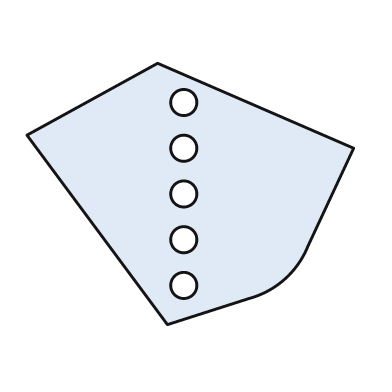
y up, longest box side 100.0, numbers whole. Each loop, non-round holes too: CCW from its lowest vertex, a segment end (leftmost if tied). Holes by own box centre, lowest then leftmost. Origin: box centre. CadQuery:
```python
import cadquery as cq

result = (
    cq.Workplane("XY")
    .moveTo(-7.0, -40.0)
    .lineTo(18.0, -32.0)
    .threePointArc((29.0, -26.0), (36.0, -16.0))
    .lineTo(50.0, 14.0)
    .lineTo(-10.0, 40.0)
    .lineTo(-50.0, 18.0)
    .close()
    .moveTo(-2.0, -28.0)
    .circle(4.0)
    .moveTo(-2.0, -14.0)
    .circle(4.0)
    .moveTo(-2.0, 0.0)
    .circle(4.0)
    .moveTo(-2.0, 14.0)
    .circle(4.0)
    .moveTo(-2.0, 28.0)
    .circle(4.0)
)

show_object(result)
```